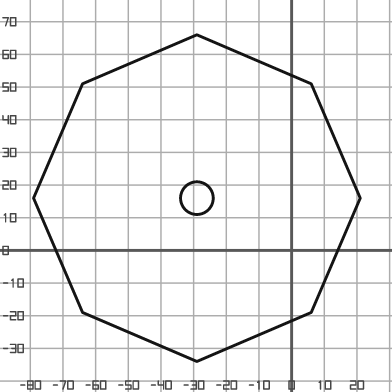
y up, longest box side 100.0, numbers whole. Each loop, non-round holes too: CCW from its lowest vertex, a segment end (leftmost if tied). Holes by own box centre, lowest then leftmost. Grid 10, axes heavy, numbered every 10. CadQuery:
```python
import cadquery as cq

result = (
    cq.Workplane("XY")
    .moveTo(-29.0, -34.0)
    .lineTo(6.0, -19.0)
    .lineTo(21.0, 16.0)
    .lineTo(6.0, 51.0)
    .lineTo(-29.0, 66.0)
    .lineTo(-64.0, 51.0)
    .lineTo(-79.0, 16.0)
    .lineTo(-64.0, -19.0)
    .close()
    .moveTo(-29.0, 16.0)
    .circle(5.0)
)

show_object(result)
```